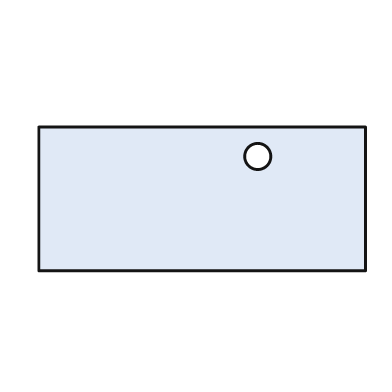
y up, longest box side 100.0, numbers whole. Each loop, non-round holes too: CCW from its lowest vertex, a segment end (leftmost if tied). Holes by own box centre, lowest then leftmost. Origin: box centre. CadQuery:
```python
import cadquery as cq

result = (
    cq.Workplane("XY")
    .moveTo(-50.0, -22.0)
    .lineTo(50.0, -22.0)
    .lineTo(50.0, 22.0)
    .lineTo(-50.0, 22.0)
    .close()
    .moveTo(17.0, 13.0)
    .circle(4.0)
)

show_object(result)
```